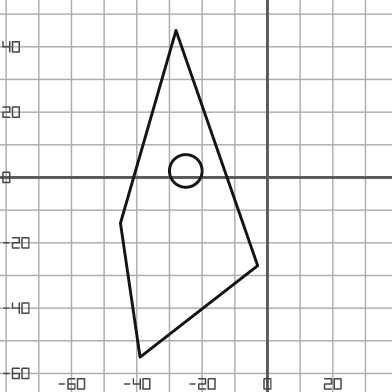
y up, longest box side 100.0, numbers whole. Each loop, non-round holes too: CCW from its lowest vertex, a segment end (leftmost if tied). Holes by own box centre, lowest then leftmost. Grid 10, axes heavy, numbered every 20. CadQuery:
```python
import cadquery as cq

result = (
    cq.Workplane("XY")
    .moveTo(-39.0, -55.0)
    .lineTo(-3.0, -27.0)
    .lineTo(-28.0, 45.0)
    .lineTo(-45.0, -14.0)
    .close()
    .moveTo(-25.0, 2.0)
    .circle(5.0)
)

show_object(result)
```